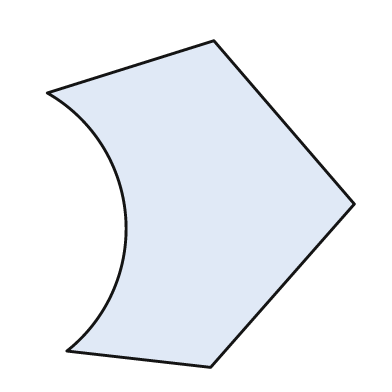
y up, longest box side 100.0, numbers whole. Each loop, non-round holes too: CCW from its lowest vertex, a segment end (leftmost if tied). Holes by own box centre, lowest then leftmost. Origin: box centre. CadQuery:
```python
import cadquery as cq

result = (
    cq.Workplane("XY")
    .moveTo(3.0, -50.0)
    .lineTo(47.0, 0.0)
    .lineTo(4.0, 50.0)
    .lineTo(-47.0, 34.0)
    .threePointArc((-23.0, -4.0), (-41.0, -45.0))
    .close()
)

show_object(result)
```